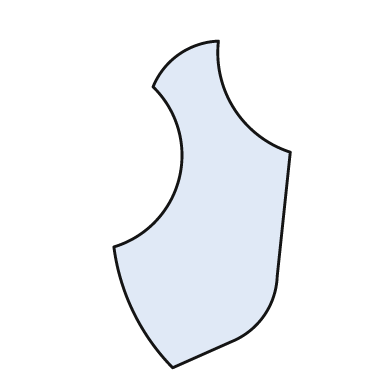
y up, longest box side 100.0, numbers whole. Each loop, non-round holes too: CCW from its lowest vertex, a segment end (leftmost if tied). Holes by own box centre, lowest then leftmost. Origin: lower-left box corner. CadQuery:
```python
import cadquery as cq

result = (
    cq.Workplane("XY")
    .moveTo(18.0, 0.0)
    .lineTo(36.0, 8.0)
    .threePointArc((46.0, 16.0), (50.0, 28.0))
    .lineTo(54.0, 66.0)
    .threePointArc((37.0, 79.0), (32.0, 100.0))
    .threePointArc((20.0, 96.0), (12.0, 86.0))
    .threePointArc((20.0, 58.0), (0.0, 37.0))
    .threePointArc((6.0, 17.0), (18.0, 0.0))
    .close()
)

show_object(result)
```